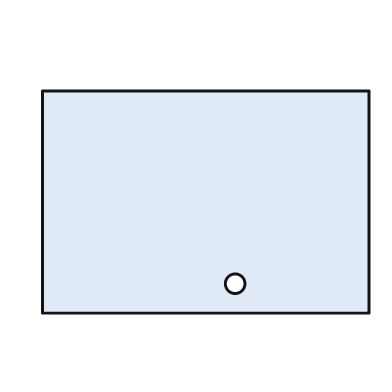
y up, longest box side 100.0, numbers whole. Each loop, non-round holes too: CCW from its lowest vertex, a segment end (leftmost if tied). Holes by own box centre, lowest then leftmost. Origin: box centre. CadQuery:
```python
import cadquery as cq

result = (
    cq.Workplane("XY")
    .moveTo(-50.0, -34.0)
    .lineTo(50.0, -34.0)
    .lineTo(50.0, 34.0)
    .lineTo(-50.0, 34.0)
    .close()
    .moveTo(9.0, -25.0)
    .circle(3.0)
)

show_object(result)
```